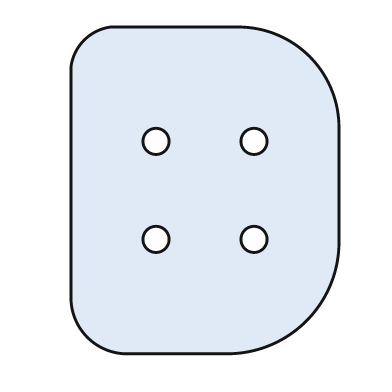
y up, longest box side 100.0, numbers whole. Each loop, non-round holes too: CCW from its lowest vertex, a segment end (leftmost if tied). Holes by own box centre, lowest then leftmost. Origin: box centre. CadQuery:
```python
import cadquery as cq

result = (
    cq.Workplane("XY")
    .moveTo(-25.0, -50.0)
    .lineTo(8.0, -50.0)
    .threePointArc((31.0, -40.0), (41.0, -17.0))
    .lineTo(41.0, 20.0)
    .threePointArc((32.0, 41.0), (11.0, 50.0))
    .lineTo(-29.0, 50.0)
    .threePointArc((-37.0, 46.0), (-41.0, 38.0))
    .lineTo(-41.0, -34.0)
    .threePointArc((-36.0, -45.0), (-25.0, -50.0))
    .close()
    .moveTo(-15.0, -15.0)
    .circle(4.0)
    .moveTo(15.0, -15.0)
    .circle(4.0)
    .moveTo(-15.0, 15.0)
    .circle(4.0)
    .moveTo(15.0, 15.0)
    .circle(4.0)
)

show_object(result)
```